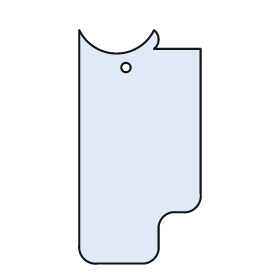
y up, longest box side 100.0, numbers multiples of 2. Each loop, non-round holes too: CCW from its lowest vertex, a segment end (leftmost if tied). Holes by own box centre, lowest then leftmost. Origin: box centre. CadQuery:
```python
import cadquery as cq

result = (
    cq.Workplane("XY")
    .moveTo(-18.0, -50.0)
    .lineTo(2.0, -50.0)
    .threePointArc((6.0, -48.0), (8.0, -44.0))
    .lineTo(8.0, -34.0)
    .threePointArc((10.0, -30.0), (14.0, -28.0))
    .lineTo(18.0, -28.0)
    .threePointArc((24.0, -26.0), (26.0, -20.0))
    .lineTo(26.0, 42.0)
    .lineTo(6.0, 42.0)
    .threePointArc((8.0, 46.0), (6.0, 50.0))
    .threePointArc((-10.0, 40.0), (-26.0, 50.0))
    .lineTo(-26.0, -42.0)
    .threePointArc((-24.0, -48.0), (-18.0, -50.0))
    .close()
    .moveTo(-6.0, 34.0)
    .circle(2.0)
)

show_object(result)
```